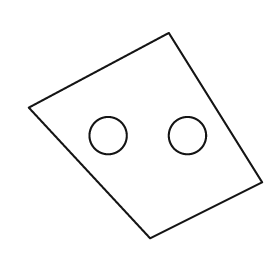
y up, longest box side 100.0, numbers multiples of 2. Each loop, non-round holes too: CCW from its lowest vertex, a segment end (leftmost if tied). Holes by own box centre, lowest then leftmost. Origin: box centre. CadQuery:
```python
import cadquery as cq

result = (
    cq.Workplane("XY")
    .moveTo(2.0, -44.0)
    .lineTo(50.0, -20.0)
    .lineTo(10.0, 44.0)
    .lineTo(-50.0, 12.0)
    .close()
    .moveTo(-16.0, 0.0)
    .circle(8.0)
    .moveTo(18.0, 0.0)
    .circle(8.0)
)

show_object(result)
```